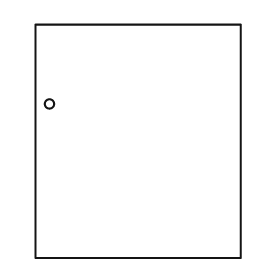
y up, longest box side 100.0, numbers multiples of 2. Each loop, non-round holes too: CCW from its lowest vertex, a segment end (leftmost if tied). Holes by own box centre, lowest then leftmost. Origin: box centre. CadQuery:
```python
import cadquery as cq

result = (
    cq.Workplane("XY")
    .moveTo(-44.0, -50.0)
    .lineTo(44.0, -50.0)
    .lineTo(44.0, 50.0)
    .lineTo(-44.0, 50.0)
    .close()
    .moveTo(-38.0, 16.0)
    .circle(2.0)
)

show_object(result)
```